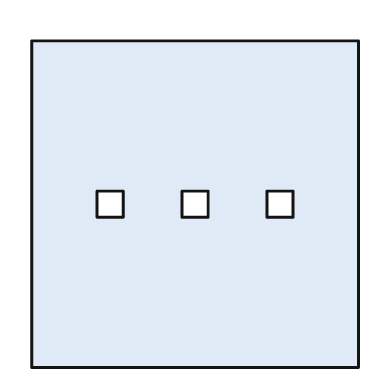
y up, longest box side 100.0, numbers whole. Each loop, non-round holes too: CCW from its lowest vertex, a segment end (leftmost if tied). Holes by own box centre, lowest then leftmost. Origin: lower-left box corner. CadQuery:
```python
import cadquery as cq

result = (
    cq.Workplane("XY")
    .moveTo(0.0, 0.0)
    .lineTo(100.0, 0.0)
    .lineTo(100.0, 100.0)
    .lineTo(0.0, 100.0)
    .close()
    .moveTo(20.0, 46.0)
    .lineTo(28.0, 46.0)
    .lineTo(28.0, 54.0)
    .lineTo(20.0, 54.0)
    .close()
    .moveTo(46.0, 46.0)
    .lineTo(54.0, 46.0)
    .lineTo(54.0, 54.0)
    .lineTo(46.0, 54.0)
    .close()
    .moveTo(72.0, 46.0)
    .lineTo(80.0, 46.0)
    .lineTo(80.0, 54.0)
    .lineTo(72.0, 54.0)
    .close()
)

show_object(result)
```